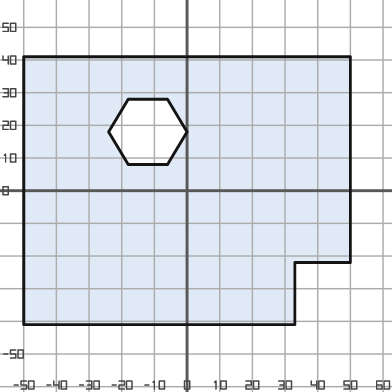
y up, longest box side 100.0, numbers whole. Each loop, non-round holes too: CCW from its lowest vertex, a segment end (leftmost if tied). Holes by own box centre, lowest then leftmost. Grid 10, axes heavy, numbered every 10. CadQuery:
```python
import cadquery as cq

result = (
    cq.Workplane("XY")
    .moveTo(-50.0, -41.0)
    .lineTo(33.0, -41.0)
    .lineTo(33.0, -22.0)
    .lineTo(50.0, -22.0)
    .lineTo(50.0, 41.0)
    .lineTo(-50.0, 41.0)
    .close()
    .moveTo(-18.0, 8.0)
    .lineTo(-6.0, 8.0)
    .lineTo(0.0, 18.0)
    .lineTo(-6.0, 28.0)
    .lineTo(-18.0, 28.0)
    .lineTo(-24.0, 18.0)
    .close()
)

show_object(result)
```